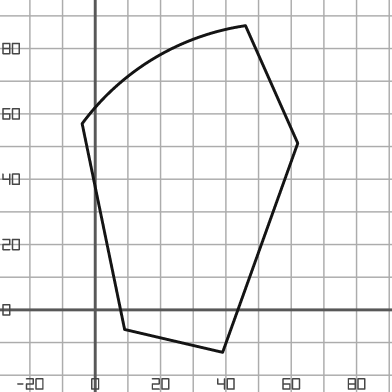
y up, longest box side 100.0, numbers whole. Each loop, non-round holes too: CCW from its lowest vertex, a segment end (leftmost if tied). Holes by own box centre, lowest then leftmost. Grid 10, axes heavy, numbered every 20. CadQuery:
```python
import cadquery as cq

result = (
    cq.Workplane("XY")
    .moveTo(39.0, -13.0)
    .lineTo(62.0, 51.0)
    .lineTo(46.0, 87.0)
    .threePointArc((18.0, 77.0), (-4.0, 57.0))
    .lineTo(9.0, -6.0)
    .close()
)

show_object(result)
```